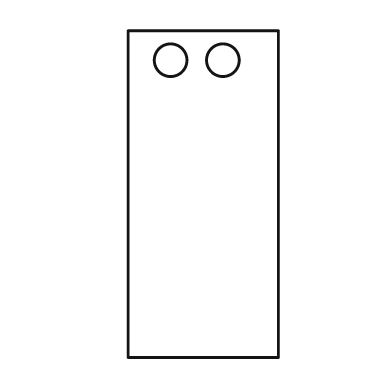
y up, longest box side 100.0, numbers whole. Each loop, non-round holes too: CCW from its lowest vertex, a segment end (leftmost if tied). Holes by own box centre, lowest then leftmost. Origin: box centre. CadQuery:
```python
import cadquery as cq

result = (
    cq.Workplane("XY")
    .moveTo(-23.0, -50.0)
    .lineTo(23.0, -50.0)
    .lineTo(23.0, 50.0)
    .lineTo(-23.0, 50.0)
    .close()
    .moveTo(-10.0, 41.0)
    .circle(5.0)
    .moveTo(6.0, 41.0)
    .circle(5.0)
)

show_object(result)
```